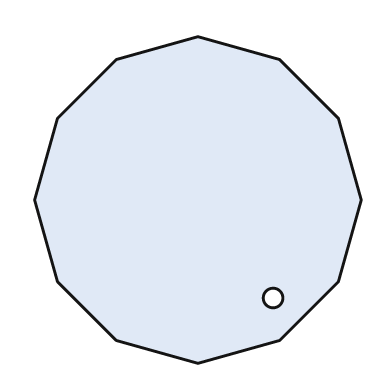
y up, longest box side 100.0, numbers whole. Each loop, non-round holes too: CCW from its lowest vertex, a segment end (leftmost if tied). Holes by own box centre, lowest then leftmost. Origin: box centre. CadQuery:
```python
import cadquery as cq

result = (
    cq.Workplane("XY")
    .moveTo(0.0, -50.0)
    .lineTo(25.0, -43.0)
    .lineTo(43.0, -25.0)
    .lineTo(50.0, 0.0)
    .lineTo(43.0, 25.0)
    .lineTo(25.0, 43.0)
    .lineTo(0.0, 50.0)
    .lineTo(-25.0, 43.0)
    .lineTo(-43.0, 25.0)
    .lineTo(-50.0, 0.0)
    .lineTo(-43.0, -25.0)
    .lineTo(-25.0, -43.0)
    .close()
    .moveTo(23.0, -30.0)
    .circle(3.0)
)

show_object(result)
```